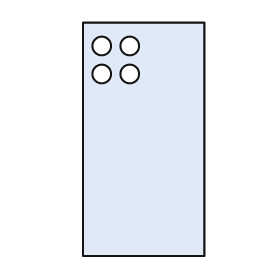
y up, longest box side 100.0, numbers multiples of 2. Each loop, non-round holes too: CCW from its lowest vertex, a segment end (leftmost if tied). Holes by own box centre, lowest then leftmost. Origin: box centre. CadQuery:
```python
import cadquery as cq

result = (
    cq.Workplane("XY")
    .moveTo(-26.0, -50.0)
    .lineTo(26.0, -50.0)
    .lineTo(26.0, 50.0)
    .lineTo(-26.0, 50.0)
    .close()
    .moveTo(-18.0, 28.0)
    .circle(4.0)
    .moveTo(-6.0, 28.0)
    .circle(4.0)
    .moveTo(-18.0, 40.0)
    .circle(4.0)
    .moveTo(-6.0, 40.0)
    .circle(4.0)
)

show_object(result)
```